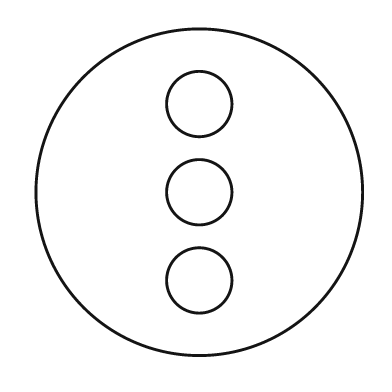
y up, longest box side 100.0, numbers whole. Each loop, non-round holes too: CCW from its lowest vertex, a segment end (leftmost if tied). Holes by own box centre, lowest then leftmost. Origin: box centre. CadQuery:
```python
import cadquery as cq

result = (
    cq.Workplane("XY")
    .moveTo(0.0, 0.0)
    .circle(50.0)
    .moveTo(0.0, -27.0)
    .circle(10.0)
    .moveTo(0.0, 0.0)
    .circle(10.0)
    .moveTo(0.0, 27.0)
    .circle(10.0)
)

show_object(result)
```